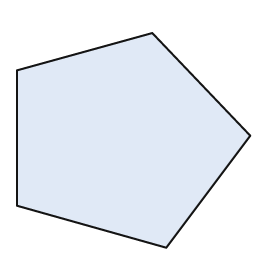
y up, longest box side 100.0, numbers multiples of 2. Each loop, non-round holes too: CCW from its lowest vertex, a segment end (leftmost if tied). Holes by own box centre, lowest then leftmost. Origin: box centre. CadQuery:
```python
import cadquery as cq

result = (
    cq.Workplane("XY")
    .moveTo(14.0, -46.0)
    .lineTo(50.0, 2.0)
    .lineTo(8.0, 46.0)
    .lineTo(-50.0, 30.0)
    .lineTo(-50.0, -28.0)
    .close()
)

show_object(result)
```